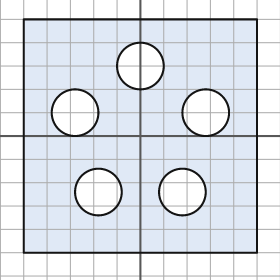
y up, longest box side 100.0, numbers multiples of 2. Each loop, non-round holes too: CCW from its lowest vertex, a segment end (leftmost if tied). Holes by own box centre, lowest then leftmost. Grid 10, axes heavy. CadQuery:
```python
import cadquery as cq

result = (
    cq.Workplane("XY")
    .moveTo(-50.0, -50.0)
    .lineTo(50.0, -50.0)
    .lineTo(50.0, 50.0)
    .lineTo(-50.0, 50.0)
    .close()
    .moveTo(-18.0, -24.0)
    .circle(10.0)
    .moveTo(18.0, -24.0)
    .circle(10.0)
    .moveTo(-28.0, 10.0)
    .circle(10.0)
    .moveTo(28.0, 10.0)
    .circle(10.0)
    .moveTo(0.0, 30.0)
    .circle(10.0)
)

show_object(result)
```